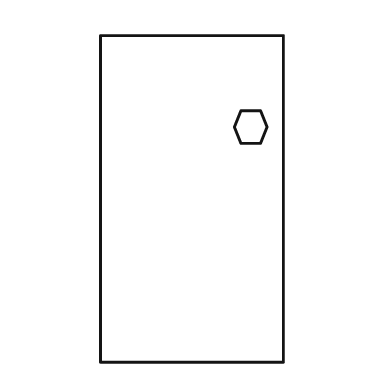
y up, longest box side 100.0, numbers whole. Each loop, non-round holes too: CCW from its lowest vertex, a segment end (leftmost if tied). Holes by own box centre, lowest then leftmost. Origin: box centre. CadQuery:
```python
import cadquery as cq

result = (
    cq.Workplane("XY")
    .moveTo(-28.0, -50.0)
    .lineTo(28.0, -50.0)
    .lineTo(28.0, 50.0)
    .lineTo(-28.0, 50.0)
    .close()
    .moveTo(15.0, 17.0)
    .lineTo(21.0, 17.0)
    .lineTo(23.0, 22.0)
    .lineTo(21.0, 27.0)
    .lineTo(15.0, 27.0)
    .lineTo(13.0, 22.0)
    .close()
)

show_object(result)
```